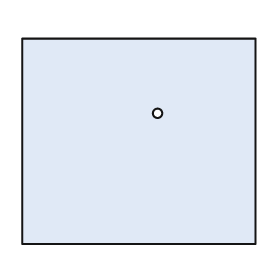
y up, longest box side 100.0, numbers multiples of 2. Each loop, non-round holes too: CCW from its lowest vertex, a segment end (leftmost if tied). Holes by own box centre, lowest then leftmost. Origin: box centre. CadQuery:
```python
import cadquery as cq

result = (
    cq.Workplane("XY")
    .moveTo(-50.0, -44.0)
    .lineTo(50.0, -44.0)
    .lineTo(50.0, 44.0)
    .lineTo(-50.0, 44.0)
    .close()
    .moveTo(8.0, 12.0)
    .circle(2.0)
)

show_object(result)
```